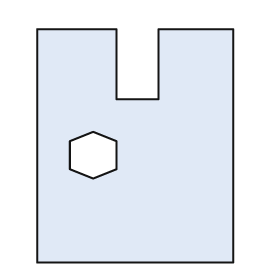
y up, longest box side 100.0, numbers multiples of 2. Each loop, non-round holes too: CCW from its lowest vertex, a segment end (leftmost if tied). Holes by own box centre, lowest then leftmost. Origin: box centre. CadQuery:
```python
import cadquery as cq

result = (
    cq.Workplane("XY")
    .moveTo(-42.0, -50.0)
    .lineTo(42.0, -50.0)
    .lineTo(42.0, 50.0)
    .lineTo(10.0, 50.0)
    .lineTo(10.0, 20.0)
    .lineTo(-8.0, 20.0)
    .lineTo(-8.0, 50.0)
    .lineTo(-42.0, 50.0)
    .close()
    .moveTo(-18.0, -14.0)
    .lineTo(-8.0, -10.0)
    .lineTo(-8.0, 2.0)
    .lineTo(-18.0, 6.0)
    .lineTo(-28.0, 2.0)
    .lineTo(-28.0, -10.0)
    .close()
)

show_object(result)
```